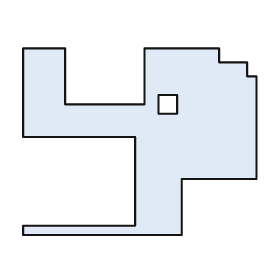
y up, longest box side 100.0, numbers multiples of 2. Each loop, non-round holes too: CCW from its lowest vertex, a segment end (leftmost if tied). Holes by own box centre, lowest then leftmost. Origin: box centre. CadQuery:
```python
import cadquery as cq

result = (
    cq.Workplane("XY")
    .moveTo(-50.0, -40.0)
    .lineTo(18.0, -40.0)
    .lineTo(18.0, -16.0)
    .lineTo(50.0, -16.0)
    .lineTo(50.0, 28.0)
    .lineTo(46.0, 28.0)
    .lineTo(46.0, 34.0)
    .lineTo(34.0, 34.0)
    .lineTo(34.0, 40.0)
    .lineTo(2.0, 40.0)
    .lineTo(2.0, 16.0)
    .lineTo(-32.0, 16.0)
    .lineTo(-32.0, 40.0)
    .lineTo(-50.0, 40.0)
    .lineTo(-50.0, 2.0)
    .lineTo(-2.0, 2.0)
    .lineTo(-2.0, -36.0)
    .lineTo(-50.0, -36.0)
    .close()
    .moveTo(8.0, 12.0)
    .lineTo(16.0, 12.0)
    .lineTo(16.0, 20.0)
    .lineTo(8.0, 20.0)
    .close()
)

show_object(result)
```